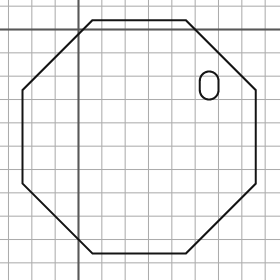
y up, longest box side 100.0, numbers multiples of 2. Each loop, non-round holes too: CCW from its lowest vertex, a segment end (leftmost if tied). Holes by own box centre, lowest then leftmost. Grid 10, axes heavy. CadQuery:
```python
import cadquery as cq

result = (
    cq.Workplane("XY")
    .moveTo(6.0, -96.0)
    .lineTo(46.0, -96.0)
    .lineTo(76.0, -66.0)
    .lineTo(76.0, -26.0)
    .lineTo(46.0, 4.0)
    .lineTo(6.0, 4.0)
    .lineTo(-24.0, -26.0)
    .lineTo(-24.0, -66.0)
    .close()
    .moveTo(52.0, -26.0)
    .threePointArc((56.0, -30.0), (60.0, -26.0))
    .lineTo(60.0, -22.0)
    .threePointArc((56.0, -18.0), (52.0, -22.0))
    .close()
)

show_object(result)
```